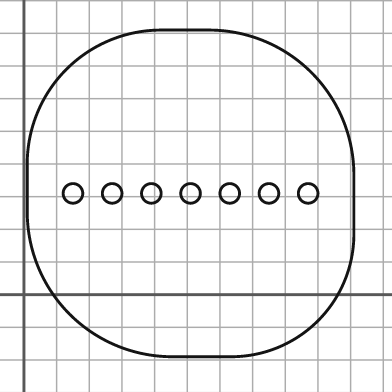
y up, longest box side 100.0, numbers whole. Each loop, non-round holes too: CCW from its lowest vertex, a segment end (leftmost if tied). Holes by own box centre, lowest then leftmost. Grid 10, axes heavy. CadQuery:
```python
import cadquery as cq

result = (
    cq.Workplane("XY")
    .moveTo(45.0, -19.0)
    .lineTo(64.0, -19.0)
    .threePointArc((90.0, -8.0), (101.0, 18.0))
    .lineTo(101.0, 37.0)
    .threePointArc((88.0, 68.0), (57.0, 81.0))
    .lineTo(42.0, 81.0)
    .threePointArc((13.0, 69.0), (1.0, 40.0))
    .lineTo(1.0, 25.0)
    .threePointArc((14.0, -6.0), (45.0, -19.0))
    .close()
    .moveTo(15.0, 31.0)
    .circle(3.0)
    .moveTo(27.0, 31.0)
    .circle(3.0)
    .moveTo(39.0, 31.0)
    .circle(3.0)
    .moveTo(51.0, 31.0)
    .circle(3.0)
    .moveTo(63.0, 31.0)
    .circle(3.0)
    .moveTo(75.0, 31.0)
    .circle(3.0)
    .moveTo(87.0, 31.0)
    .circle(3.0)
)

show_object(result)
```